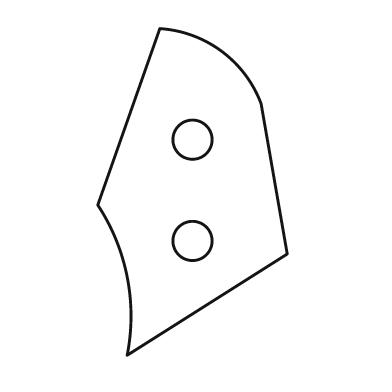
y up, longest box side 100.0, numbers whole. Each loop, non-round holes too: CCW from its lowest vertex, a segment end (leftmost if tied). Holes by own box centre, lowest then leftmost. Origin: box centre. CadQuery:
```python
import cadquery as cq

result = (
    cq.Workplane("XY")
    .moveTo(-20.0, -50.0)
    .lineTo(29.0, -19.0)
    .lineTo(21.0, 27.0)
    .threePointArc((9.0, 43.0), (-10.0, 50.0))
    .lineTo(-29.0, -4.0)
    .threePointArc((-20.0, -26.0), (-20.0, -50.0))
    .close()
    .moveTo(0.0, -15.0)
    .circle(6.0)
    .moveTo(0.0, 16.0)
    .circle(6.0)
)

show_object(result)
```